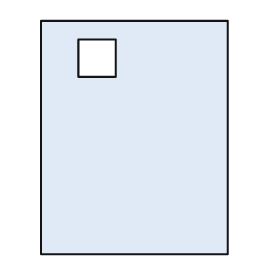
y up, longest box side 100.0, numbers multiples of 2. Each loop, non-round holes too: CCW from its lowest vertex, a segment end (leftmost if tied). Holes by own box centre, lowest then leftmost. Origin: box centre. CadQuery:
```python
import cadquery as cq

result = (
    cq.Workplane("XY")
    .moveTo(-40.0, -50.0)
    .lineTo(40.0, -50.0)
    .lineTo(40.0, 50.0)
    .lineTo(-40.0, 50.0)
    .close()
    .moveTo(-24.0, 26.0)
    .lineTo(-8.0, 26.0)
    .lineTo(-8.0, 42.0)
    .lineTo(-24.0, 42.0)
    .close()
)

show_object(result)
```